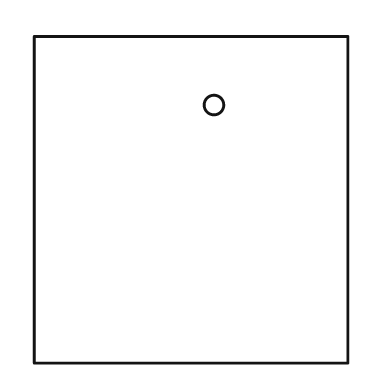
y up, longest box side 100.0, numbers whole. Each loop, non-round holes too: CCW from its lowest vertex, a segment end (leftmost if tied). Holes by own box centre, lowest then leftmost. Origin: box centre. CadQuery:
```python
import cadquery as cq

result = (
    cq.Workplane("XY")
    .moveTo(-48.0, -50.0)
    .lineTo(48.0, -50.0)
    .lineTo(48.0, 50.0)
    .lineTo(-48.0, 50.0)
    .close()
    .moveTo(7.0, 29.0)
    .circle(3.0)
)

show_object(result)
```